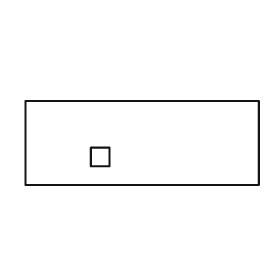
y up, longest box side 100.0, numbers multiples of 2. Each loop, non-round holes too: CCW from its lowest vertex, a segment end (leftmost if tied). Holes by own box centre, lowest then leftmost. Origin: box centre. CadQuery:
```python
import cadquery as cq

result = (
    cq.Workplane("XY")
    .moveTo(-50.0, -18.0)
    .lineTo(50.0, -18.0)
    .lineTo(50.0, 18.0)
    .lineTo(-50.0, 18.0)
    .close()
    .moveTo(-22.0, -10.0)
    .lineTo(-14.0, -10.0)
    .lineTo(-14.0, -2.0)
    .lineTo(-22.0, -2.0)
    .close()
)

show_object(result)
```